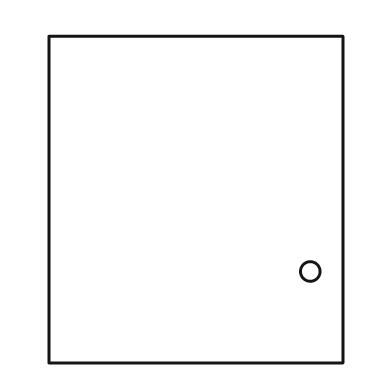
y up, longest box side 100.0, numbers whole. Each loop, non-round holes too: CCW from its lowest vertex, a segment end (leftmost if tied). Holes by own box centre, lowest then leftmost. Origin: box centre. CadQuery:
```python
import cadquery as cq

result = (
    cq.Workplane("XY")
    .moveTo(-45.0, -50.0)
    .lineTo(45.0, -50.0)
    .lineTo(45.0, 50.0)
    .lineTo(-45.0, 50.0)
    .close()
    .moveTo(35.0, -22.0)
    .circle(3.0)
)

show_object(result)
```